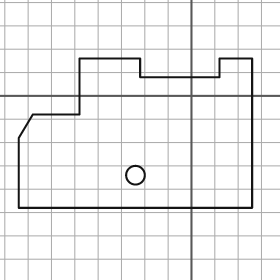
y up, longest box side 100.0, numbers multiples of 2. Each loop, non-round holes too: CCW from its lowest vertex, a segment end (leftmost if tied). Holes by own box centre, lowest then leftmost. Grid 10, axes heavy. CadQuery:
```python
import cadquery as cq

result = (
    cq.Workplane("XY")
    .moveTo(-74.0, -48.0)
    .lineTo(26.0, -48.0)
    .lineTo(26.0, 16.0)
    .lineTo(12.0, 16.0)
    .lineTo(12.0, 8.0)
    .lineTo(-22.0, 8.0)
    .lineTo(-22.0, 16.0)
    .lineTo(-48.0, 16.0)
    .lineTo(-48.0, -8.0)
    .lineTo(-68.0, -8.0)
    .lineTo(-74.0, -18.0)
    .close()
    .moveTo(-24.0, -34.0)
    .circle(4.0)
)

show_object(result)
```